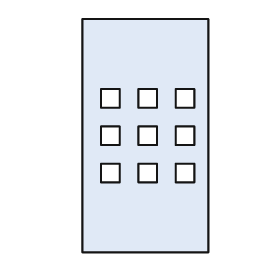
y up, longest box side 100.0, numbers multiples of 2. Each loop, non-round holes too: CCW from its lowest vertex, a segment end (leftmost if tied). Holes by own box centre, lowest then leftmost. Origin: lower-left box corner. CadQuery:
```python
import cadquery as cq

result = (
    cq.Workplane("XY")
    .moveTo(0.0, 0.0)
    .lineTo(54.0, 0.0)
    .lineTo(54.0, 100.0)
    .lineTo(0.0, 100.0)
    .close()
    .moveTo(8.0, 30.0)
    .lineTo(16.0, 30.0)
    .lineTo(16.0, 38.0)
    .lineTo(8.0, 38.0)
    .close()
    .moveTo(24.0, 30.0)
    .lineTo(32.0, 30.0)
    .lineTo(32.0, 38.0)
    .lineTo(24.0, 38.0)
    .close()
    .moveTo(40.0, 30.0)
    .lineTo(48.0, 30.0)
    .lineTo(48.0, 38.0)
    .lineTo(40.0, 38.0)
    .close()
    .moveTo(8.0, 46.0)
    .lineTo(16.0, 46.0)
    .lineTo(16.0, 54.0)
    .lineTo(8.0, 54.0)
    .close()
    .moveTo(24.0, 46.0)
    .lineTo(32.0, 46.0)
    .lineTo(32.0, 54.0)
    .lineTo(24.0, 54.0)
    .close()
    .moveTo(40.0, 46.0)
    .lineTo(48.0, 46.0)
    .lineTo(48.0, 54.0)
    .lineTo(40.0, 54.0)
    .close()
    .moveTo(8.0, 62.0)
    .lineTo(16.0, 62.0)
    .lineTo(16.0, 70.0)
    .lineTo(8.0, 70.0)
    .close()
    .moveTo(24.0, 62.0)
    .lineTo(32.0, 62.0)
    .lineTo(32.0, 70.0)
    .lineTo(24.0, 70.0)
    .close()
    .moveTo(40.0, 62.0)
    .lineTo(48.0, 62.0)
    .lineTo(48.0, 70.0)
    .lineTo(40.0, 70.0)
    .close()
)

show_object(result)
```